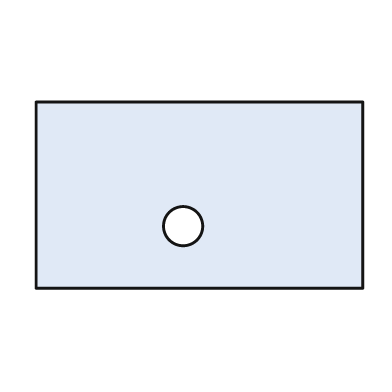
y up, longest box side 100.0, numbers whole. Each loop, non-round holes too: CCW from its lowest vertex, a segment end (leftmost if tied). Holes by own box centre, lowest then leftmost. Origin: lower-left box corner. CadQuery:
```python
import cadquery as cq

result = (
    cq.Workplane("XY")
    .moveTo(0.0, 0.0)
    .lineTo(100.0, 0.0)
    .lineTo(100.0, 57.0)
    .lineTo(0.0, 57.0)
    .close()
    .moveTo(45.0, 19.0)
    .circle(6.0)
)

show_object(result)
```